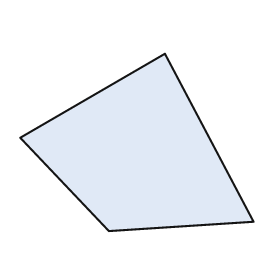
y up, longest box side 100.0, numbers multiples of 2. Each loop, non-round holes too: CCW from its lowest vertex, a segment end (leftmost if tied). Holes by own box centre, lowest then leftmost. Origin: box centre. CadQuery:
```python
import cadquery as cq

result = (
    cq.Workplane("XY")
    .moveTo(-12.0, -38.0)
    .lineTo(50.0, -34.0)
    .lineTo(12.0, 38.0)
    .lineTo(-50.0, 2.0)
    .close()
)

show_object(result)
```